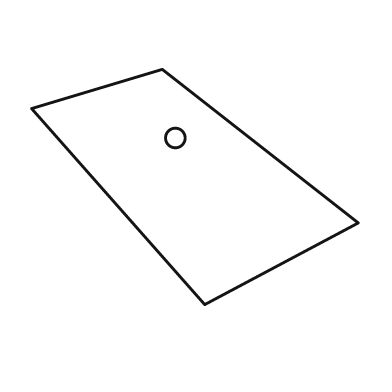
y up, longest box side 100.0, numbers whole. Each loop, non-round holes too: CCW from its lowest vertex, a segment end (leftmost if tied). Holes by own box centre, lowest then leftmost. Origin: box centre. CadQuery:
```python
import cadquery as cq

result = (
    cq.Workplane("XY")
    .moveTo(3.0, -36.0)
    .lineTo(50.0, -11.0)
    .lineTo(-10.0, 36.0)
    .lineTo(-50.0, 24.0)
    .close()
    .moveTo(-6.0, 15.0)
    .circle(3.0)
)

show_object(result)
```